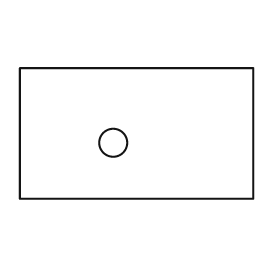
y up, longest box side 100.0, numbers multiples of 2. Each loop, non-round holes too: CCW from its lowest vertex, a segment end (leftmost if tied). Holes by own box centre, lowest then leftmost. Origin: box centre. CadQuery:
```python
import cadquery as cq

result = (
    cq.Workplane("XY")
    .moveTo(-50.0, -28.0)
    .lineTo(50.0, -28.0)
    .lineTo(50.0, 28.0)
    .lineTo(-50.0, 28.0)
    .close()
    .moveTo(-10.0, -4.0)
    .circle(6.0)
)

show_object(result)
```